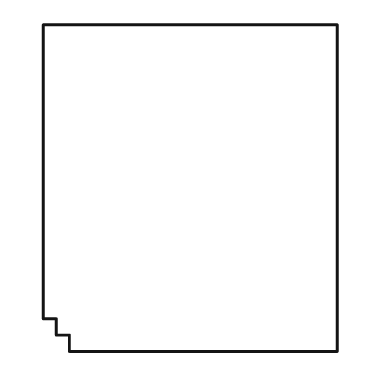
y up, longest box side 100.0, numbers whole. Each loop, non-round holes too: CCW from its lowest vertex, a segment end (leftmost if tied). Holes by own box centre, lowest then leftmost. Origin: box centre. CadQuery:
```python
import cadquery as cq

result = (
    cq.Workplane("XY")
    .moveTo(-37.0, -50.0)
    .lineTo(45.0, -50.0)
    .lineTo(45.0, 50.0)
    .lineTo(-45.0, 50.0)
    .lineTo(-45.0, -40.0)
    .lineTo(-41.0, -40.0)
    .lineTo(-41.0, -45.0)
    .lineTo(-37.0, -45.0)
    .close()
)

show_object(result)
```